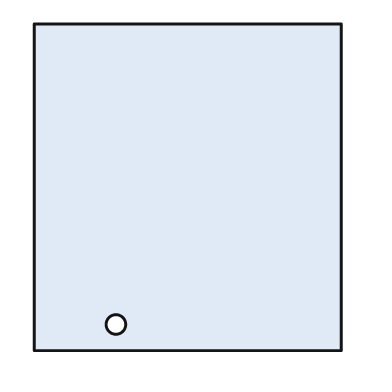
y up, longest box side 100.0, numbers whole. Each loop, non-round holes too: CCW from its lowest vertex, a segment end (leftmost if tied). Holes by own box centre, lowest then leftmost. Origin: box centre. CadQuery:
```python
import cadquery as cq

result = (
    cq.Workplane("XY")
    .moveTo(-47.0, -50.0)
    .lineTo(47.0, -50.0)
    .lineTo(47.0, 50.0)
    .lineTo(-47.0, 50.0)
    .close()
    .moveTo(-22.0, -42.0)
    .circle(3.0)
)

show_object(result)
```